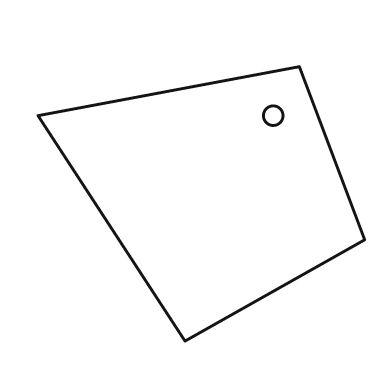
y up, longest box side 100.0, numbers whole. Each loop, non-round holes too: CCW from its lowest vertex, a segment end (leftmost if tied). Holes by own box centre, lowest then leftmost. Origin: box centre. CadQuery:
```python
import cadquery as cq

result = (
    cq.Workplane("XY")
    .moveTo(-5.0, -42.0)
    .lineTo(50.0, -11.0)
    .lineTo(30.0, 42.0)
    .lineTo(-50.0, 27.0)
    .close()
    .moveTo(22.0, 27.0)
    .circle(3.0)
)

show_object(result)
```